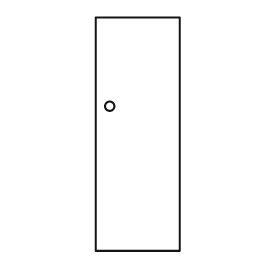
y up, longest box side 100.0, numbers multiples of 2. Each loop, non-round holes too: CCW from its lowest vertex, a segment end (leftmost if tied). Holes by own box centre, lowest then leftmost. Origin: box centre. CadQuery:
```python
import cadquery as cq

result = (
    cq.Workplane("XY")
    .moveTo(-18.0, -50.0)
    .lineTo(18.0, -50.0)
    .lineTo(18.0, 50.0)
    .lineTo(-18.0, 50.0)
    .close()
    .moveTo(-12.0, 12.0)
    .circle(2.0)
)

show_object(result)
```